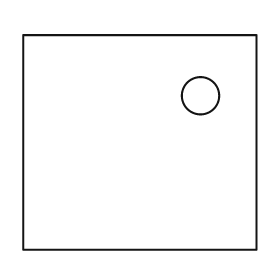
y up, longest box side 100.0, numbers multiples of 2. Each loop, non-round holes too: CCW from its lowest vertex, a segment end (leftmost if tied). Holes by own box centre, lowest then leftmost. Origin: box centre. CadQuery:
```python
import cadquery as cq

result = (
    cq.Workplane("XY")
    .moveTo(-50.0, -46.0)
    .lineTo(50.0, -46.0)
    .lineTo(50.0, 46.0)
    .lineTo(-50.0, 46.0)
    .close()
    .moveTo(26.0, 20.0)
    .circle(8.0)
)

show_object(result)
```